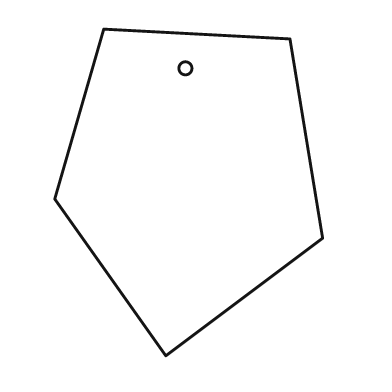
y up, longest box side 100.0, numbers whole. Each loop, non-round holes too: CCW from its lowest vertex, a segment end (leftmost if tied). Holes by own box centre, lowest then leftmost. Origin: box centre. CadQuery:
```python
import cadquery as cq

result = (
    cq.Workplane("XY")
    .moveTo(-7.0, -50.0)
    .lineTo(41.0, -14.0)
    .lineTo(31.0, 47.0)
    .lineTo(-26.0, 50.0)
    .lineTo(-41.0, -2.0)
    .close()
    .moveTo(-1.0, 38.0)
    .circle(2.0)
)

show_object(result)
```